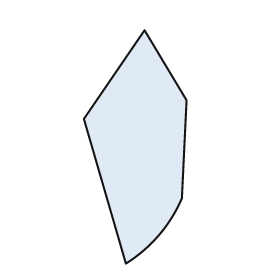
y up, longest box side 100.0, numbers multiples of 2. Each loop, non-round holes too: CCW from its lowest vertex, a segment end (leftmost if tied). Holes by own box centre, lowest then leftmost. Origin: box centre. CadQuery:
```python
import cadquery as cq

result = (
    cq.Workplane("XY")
    .moveTo(-4.0, -50.0)
    .threePointArc((10.0, -38.0), (20.0, -22.0))
    .lineTo(22.0, 20.0)
    .lineTo(4.0, 50.0)
    .lineTo(-22.0, 12.0)
    .close()
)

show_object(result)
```